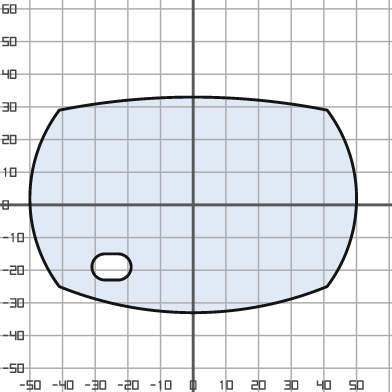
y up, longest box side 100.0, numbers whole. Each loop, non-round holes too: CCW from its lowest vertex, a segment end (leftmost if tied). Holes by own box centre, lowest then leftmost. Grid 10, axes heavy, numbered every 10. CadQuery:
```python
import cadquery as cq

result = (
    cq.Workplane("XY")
    .moveTo(-41.0, -25.0)
    .threePointArc((0.0, -33.0), (41.0, -25.0))
    .threePointArc((50.0, 2.0), (41.0, 29.0))
    .threePointArc((0.0, 33.0), (-41.0, 29.0))
    .threePointArc((-50.0, 2.0), (-41.0, -25.0))
    .close()
    .moveTo(-27.0, -23.0)
    .lineTo(-23.0, -23.0)
    .threePointArc((-19.0, -19.0), (-23.0, -15.0))
    .lineTo(-27.0, -15.0)
    .threePointArc((-31.0, -19.0), (-27.0, -23.0))
    .close()
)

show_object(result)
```